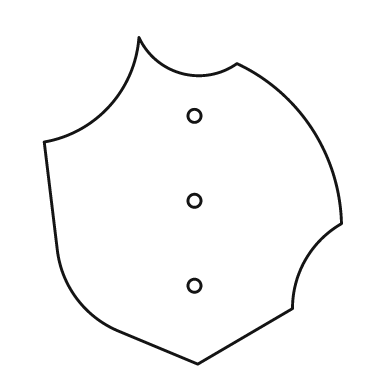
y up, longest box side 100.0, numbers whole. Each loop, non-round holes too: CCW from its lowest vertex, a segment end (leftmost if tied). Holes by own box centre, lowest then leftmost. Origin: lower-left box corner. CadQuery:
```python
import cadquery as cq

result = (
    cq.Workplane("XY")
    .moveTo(47.0, 0.0)
    .lineTo(76.0, 17.0)
    .threePointArc((80.0, 32.0), (91.0, 43.0))
    .threePointArc((82.0, 72.0), (59.0, 92.0))
    .threePointArc((42.0, 89.0), (29.0, 100.0))
    .threePointArc((20.0, 79.0), (0.0, 68.0))
    .lineTo(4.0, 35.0)
    .threePointArc((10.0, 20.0), (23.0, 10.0))
    .close()
    .moveTo(46.0, 24.0)
    .circle(2.0)
    .moveTo(46.0, 50.0)
    .circle(2.0)
    .moveTo(46.0, 76.0)
    .circle(2.0)
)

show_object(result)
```